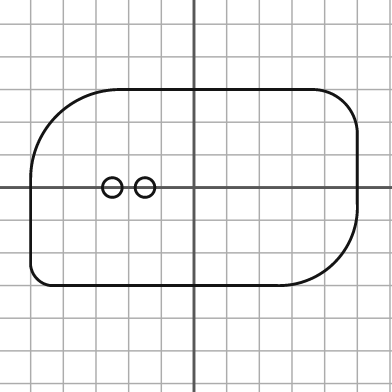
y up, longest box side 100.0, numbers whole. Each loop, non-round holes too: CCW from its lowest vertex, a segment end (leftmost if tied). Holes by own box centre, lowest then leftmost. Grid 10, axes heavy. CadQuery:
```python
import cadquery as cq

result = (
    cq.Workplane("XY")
    .moveTo(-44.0, -30.0)
    .lineTo(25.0, -30.0)
    .threePointArc((43.0, -23.0), (50.0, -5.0))
    .lineTo(50.0, 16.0)
    .threePointArc((46.0, 26.0), (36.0, 30.0))
    .lineTo(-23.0, 30.0)
    .threePointArc((-42.0, 22.0), (-50.0, 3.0))
    .lineTo(-50.0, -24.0)
    .threePointArc((-48.0, -28.0), (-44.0, -30.0))
    .close()
    .moveTo(-25.0, 0.0)
    .circle(3.0)
    .moveTo(-15.0, 0.0)
    .circle(3.0)
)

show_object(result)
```